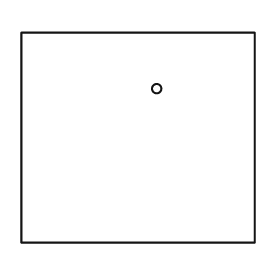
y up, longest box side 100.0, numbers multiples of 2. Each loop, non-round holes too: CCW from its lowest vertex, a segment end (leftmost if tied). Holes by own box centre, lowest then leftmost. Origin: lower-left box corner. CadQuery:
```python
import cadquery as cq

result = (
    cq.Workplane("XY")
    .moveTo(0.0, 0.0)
    .lineTo(100.0, 0.0)
    .lineTo(100.0, 90.0)
    .lineTo(0.0, 90.0)
    .close()
    .moveTo(58.0, 66.0)
    .circle(2.0)
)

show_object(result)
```